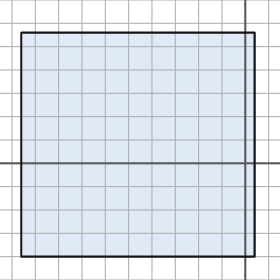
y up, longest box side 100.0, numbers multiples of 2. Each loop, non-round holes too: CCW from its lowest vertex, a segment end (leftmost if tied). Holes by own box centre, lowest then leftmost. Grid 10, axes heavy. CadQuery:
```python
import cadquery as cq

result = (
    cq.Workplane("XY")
    .moveTo(-96.0, -40.0)
    .lineTo(4.0, -40.0)
    .lineTo(4.0, 56.0)
    .lineTo(-96.0, 56.0)
    .close()
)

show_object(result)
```